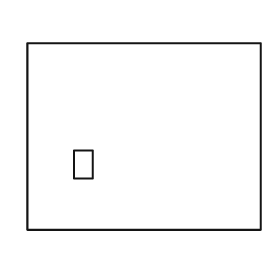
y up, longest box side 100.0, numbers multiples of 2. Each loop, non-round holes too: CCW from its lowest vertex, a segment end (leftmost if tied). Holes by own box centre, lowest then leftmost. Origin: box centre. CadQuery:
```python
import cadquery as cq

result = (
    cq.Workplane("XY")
    .moveTo(-50.0, -40.0)
    .lineTo(50.0, -40.0)
    .lineTo(50.0, 40.0)
    .lineTo(-50.0, 40.0)
    .close()
    .moveTo(-30.0, -18.0)
    .lineTo(-22.0, -18.0)
    .lineTo(-22.0, -6.0)
    .lineTo(-30.0, -6.0)
    .close()
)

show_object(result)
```